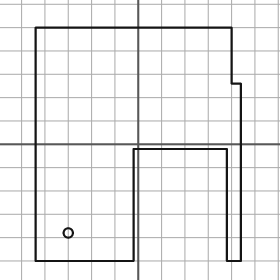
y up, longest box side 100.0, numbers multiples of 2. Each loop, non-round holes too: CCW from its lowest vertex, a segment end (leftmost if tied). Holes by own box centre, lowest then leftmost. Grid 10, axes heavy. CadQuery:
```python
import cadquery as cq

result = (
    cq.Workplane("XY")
    .moveTo(-44.0, -50.0)
    .lineTo(-2.0, -50.0)
    .lineTo(-2.0, -2.0)
    .lineTo(38.0, -2.0)
    .lineTo(38.0, -50.0)
    .lineTo(44.0, -50.0)
    .lineTo(44.0, 26.0)
    .lineTo(40.0, 26.0)
    .lineTo(40.0, 50.0)
    .lineTo(-44.0, 50.0)
    .close()
    .moveTo(-30.0, -38.0)
    .circle(2.0)
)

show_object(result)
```